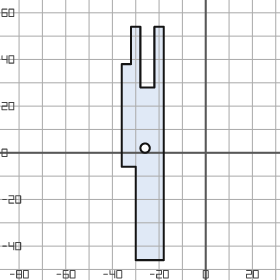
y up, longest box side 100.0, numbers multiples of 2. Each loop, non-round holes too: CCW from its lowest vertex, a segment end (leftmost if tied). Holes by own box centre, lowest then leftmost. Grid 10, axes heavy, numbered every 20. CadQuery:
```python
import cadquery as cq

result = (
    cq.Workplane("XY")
    .moveTo(-30.0, -46.0)
    .lineTo(-18.0, -46.0)
    .lineTo(-18.0, 54.0)
    .lineTo(-22.0, 54.0)
    .lineTo(-22.0, 28.0)
    .lineTo(-28.0, 28.0)
    .lineTo(-28.0, 54.0)
    .lineTo(-32.0, 54.0)
    .lineTo(-32.0, 38.0)
    .lineTo(-36.0, 38.0)
    .lineTo(-36.0, -6.0)
    .lineTo(-30.0, -6.0)
    .close()
    .moveTo(-26.0, 2.0)
    .circle(2.0)
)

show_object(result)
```